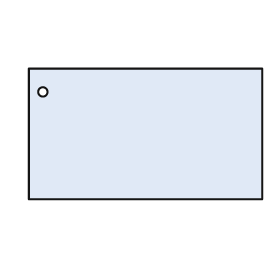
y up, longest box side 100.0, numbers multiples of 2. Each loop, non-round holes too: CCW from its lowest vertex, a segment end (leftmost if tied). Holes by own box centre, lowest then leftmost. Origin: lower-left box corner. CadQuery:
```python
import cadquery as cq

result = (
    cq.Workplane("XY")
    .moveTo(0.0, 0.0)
    .lineTo(100.0, 0.0)
    .lineTo(100.0, 56.0)
    .lineTo(0.0, 56.0)
    .close()
    .moveTo(6.0, 46.0)
    .circle(2.0)
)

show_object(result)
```